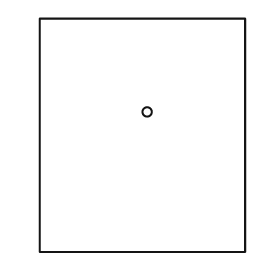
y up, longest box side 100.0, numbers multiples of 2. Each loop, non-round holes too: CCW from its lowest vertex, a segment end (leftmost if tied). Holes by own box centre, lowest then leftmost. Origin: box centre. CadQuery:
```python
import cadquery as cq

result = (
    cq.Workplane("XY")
    .moveTo(-44.0, -50.0)
    .lineTo(44.0, -50.0)
    .lineTo(44.0, 50.0)
    .lineTo(-44.0, 50.0)
    .close()
    .moveTo(2.0, 10.0)
    .circle(2.0)
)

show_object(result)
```